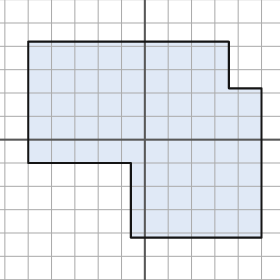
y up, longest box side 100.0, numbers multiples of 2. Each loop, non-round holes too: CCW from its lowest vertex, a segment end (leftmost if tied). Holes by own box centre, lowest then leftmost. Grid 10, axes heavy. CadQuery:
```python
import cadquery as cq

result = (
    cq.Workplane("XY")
    .moveTo(-6.0, -42.0)
    .lineTo(50.0, -42.0)
    .lineTo(50.0, 22.0)
    .lineTo(36.0, 22.0)
    .lineTo(36.0, 42.0)
    .lineTo(-50.0, 42.0)
    .lineTo(-50.0, -10.0)
    .lineTo(-6.0, -10.0)
    .close()
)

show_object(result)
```